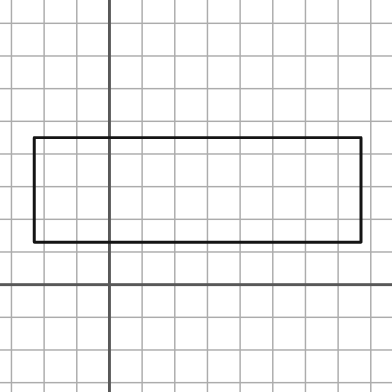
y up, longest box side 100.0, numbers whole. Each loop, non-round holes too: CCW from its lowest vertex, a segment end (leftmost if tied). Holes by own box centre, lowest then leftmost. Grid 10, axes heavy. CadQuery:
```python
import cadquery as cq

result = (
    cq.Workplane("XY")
    .moveTo(-23.0, 13.0)
    .lineTo(77.0, 13.0)
    .lineTo(77.0, 45.0)
    .lineTo(-23.0, 45.0)
    .close()
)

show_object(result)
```